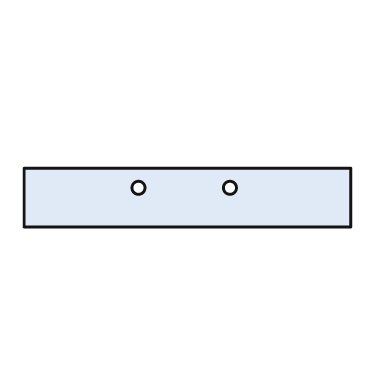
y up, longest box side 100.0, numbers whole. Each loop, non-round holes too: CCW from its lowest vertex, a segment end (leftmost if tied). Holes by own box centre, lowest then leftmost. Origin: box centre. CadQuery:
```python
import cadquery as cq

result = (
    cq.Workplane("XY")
    .moveTo(-50.0, -9.0)
    .lineTo(50.0, -9.0)
    .lineTo(50.0, 9.0)
    .lineTo(-50.0, 9.0)
    .close()
    .moveTo(-15.0, 3.0)
    .circle(2.0)
    .moveTo(13.0, 3.0)
    .circle(2.0)
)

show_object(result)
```